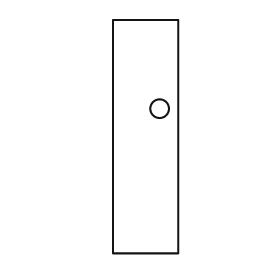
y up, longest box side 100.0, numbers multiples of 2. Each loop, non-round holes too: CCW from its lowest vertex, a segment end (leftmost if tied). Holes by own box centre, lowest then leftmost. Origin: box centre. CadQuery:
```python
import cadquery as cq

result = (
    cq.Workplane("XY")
    .moveTo(-14.0, -50.0)
    .lineTo(14.0, -50.0)
    .lineTo(14.0, 50.0)
    .lineTo(-14.0, 50.0)
    .close()
    .moveTo(6.0, 12.0)
    .circle(4.0)
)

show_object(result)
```